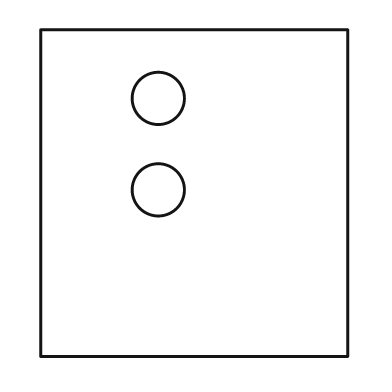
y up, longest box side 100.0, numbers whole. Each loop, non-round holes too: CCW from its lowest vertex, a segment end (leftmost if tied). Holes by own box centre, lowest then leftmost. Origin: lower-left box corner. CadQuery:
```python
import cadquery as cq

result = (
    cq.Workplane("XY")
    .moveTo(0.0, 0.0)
    .lineTo(94.0, 0.0)
    .lineTo(94.0, 100.0)
    .lineTo(0.0, 100.0)
    .close()
    .moveTo(36.0, 51.0)
    .circle(8.0)
    .moveTo(36.0, 79.0)
    .circle(8.0)
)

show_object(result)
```